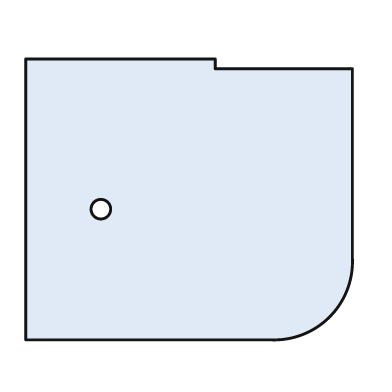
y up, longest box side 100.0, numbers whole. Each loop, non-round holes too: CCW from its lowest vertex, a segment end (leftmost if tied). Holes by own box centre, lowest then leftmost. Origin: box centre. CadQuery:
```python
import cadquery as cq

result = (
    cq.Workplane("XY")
    .moveTo(-50.0, -43.0)
    .lineTo(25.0, -43.0)
    .threePointArc((43.0, -36.0), (50.0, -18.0))
    .lineTo(50.0, 40.0)
    .lineTo(8.0, 40.0)
    .lineTo(8.0, 43.0)
    .lineTo(-50.0, 43.0)
    .close()
    .moveTo(-27.0, -3.0)
    .circle(3.0)
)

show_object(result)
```